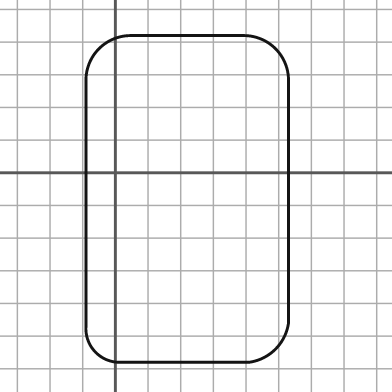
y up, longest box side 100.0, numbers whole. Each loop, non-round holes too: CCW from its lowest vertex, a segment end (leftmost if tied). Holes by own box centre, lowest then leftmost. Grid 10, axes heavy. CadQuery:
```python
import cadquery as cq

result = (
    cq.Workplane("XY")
    .moveTo(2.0, -58.0)
    .lineTo(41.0, -58.0)
    .threePointArc((49.0, -54.0), (53.0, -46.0))
    .lineTo(53.0, 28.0)
    .threePointArc((49.0, 38.0), (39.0, 42.0))
    .lineTo(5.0, 42.0)
    .threePointArc((-5.0, 38.0), (-9.0, 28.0))
    .lineTo(-9.0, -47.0)
    .threePointArc((-6.0, -55.0), (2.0, -58.0))
    .close()
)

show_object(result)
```